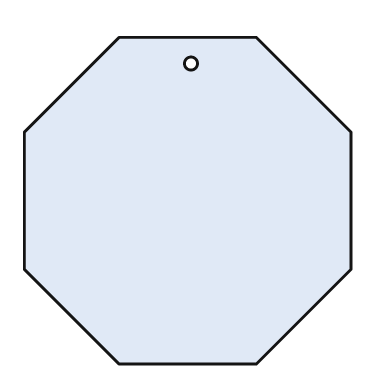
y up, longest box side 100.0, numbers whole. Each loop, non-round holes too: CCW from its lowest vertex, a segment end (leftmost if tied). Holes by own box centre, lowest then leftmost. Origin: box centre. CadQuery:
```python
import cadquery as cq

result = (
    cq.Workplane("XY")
    .moveTo(-21.0, -50.0)
    .lineTo(21.0, -50.0)
    .lineTo(50.0, -21.0)
    .lineTo(50.0, 21.0)
    .lineTo(21.0, 50.0)
    .lineTo(-21.0, 50.0)
    .lineTo(-50.0, 21.0)
    .lineTo(-50.0, -21.0)
    .close()
    .moveTo(1.0, 42.0)
    .circle(2.0)
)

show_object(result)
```